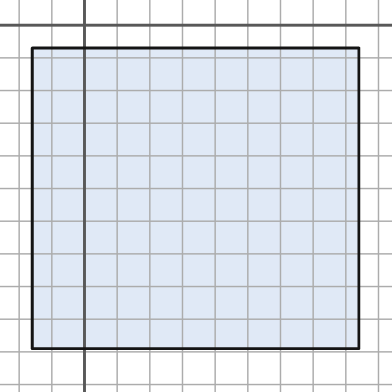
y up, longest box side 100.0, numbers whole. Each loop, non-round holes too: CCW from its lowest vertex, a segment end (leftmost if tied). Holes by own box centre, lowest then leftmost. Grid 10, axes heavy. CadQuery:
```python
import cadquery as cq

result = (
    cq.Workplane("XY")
    .moveTo(-16.0, -99.0)
    .lineTo(84.0, -99.0)
    .lineTo(84.0, -7.0)
    .lineTo(-16.0, -7.0)
    .close()
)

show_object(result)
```